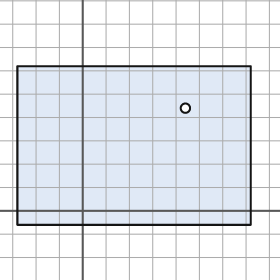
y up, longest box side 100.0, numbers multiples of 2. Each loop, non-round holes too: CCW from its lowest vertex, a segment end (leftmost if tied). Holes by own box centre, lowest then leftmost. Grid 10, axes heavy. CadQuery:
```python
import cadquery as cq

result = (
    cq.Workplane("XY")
    .moveTo(-28.0, -6.0)
    .lineTo(72.0, -6.0)
    .lineTo(72.0, 62.0)
    .lineTo(-28.0, 62.0)
    .close()
    .moveTo(44.0, 44.0)
    .circle(2.0)
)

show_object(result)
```